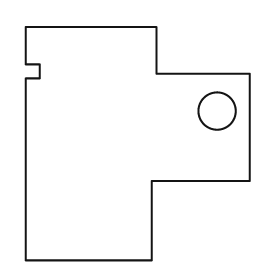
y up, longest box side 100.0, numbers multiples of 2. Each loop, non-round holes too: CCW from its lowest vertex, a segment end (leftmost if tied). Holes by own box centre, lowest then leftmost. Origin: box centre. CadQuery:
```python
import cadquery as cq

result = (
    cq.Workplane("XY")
    .moveTo(-48.0, -50.0)
    .lineTo(6.0, -50.0)
    .lineTo(6.0, -16.0)
    .lineTo(48.0, -16.0)
    .lineTo(48.0, 30.0)
    .lineTo(8.0, 30.0)
    .lineTo(8.0, 50.0)
    .lineTo(-48.0, 50.0)
    .lineTo(-48.0, 34.0)
    .lineTo(-42.0, 34.0)
    .lineTo(-42.0, 28.0)
    .lineTo(-48.0, 28.0)
    .close()
    .moveTo(34.0, 14.0)
    .circle(8.0)
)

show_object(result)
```